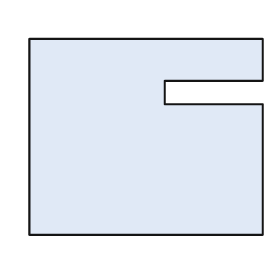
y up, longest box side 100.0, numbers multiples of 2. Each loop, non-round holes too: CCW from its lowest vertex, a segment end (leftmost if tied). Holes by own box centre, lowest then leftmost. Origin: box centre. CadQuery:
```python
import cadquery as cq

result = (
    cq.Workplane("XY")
    .moveTo(-50.0, -42.0)
    .lineTo(50.0, -42.0)
    .lineTo(50.0, 14.0)
    .lineTo(8.0, 14.0)
    .lineTo(8.0, 24.0)
    .lineTo(50.0, 24.0)
    .lineTo(50.0, 42.0)
    .lineTo(-50.0, 42.0)
    .close()
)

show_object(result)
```